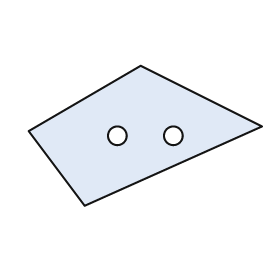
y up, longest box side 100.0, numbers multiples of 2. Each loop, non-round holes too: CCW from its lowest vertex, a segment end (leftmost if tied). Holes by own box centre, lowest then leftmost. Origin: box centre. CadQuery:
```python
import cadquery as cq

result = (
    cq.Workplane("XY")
    .moveTo(-26.0, -30.0)
    .lineTo(50.0, 4.0)
    .lineTo(-2.0, 30.0)
    .lineTo(-50.0, 2.0)
    .close()
    .moveTo(-12.0, 0.0)
    .circle(4.0)
    .moveTo(12.0, 0.0)
    .circle(4.0)
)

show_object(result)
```